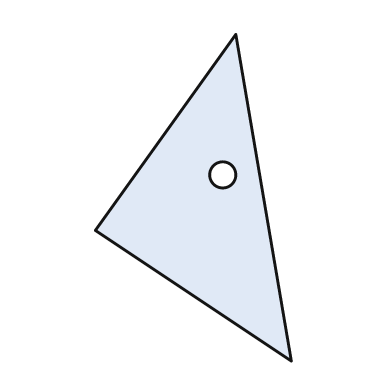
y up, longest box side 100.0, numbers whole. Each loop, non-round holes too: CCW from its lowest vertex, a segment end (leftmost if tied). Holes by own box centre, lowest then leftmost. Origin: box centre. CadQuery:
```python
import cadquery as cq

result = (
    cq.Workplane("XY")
    .moveTo(30.0, -50.0)
    .lineTo(13.0, 50.0)
    .lineTo(-30.0, -10.0)
    .close()
    .moveTo(9.0, 7.0)
    .circle(4.0)
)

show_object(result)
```